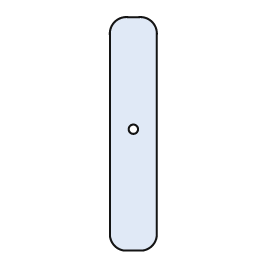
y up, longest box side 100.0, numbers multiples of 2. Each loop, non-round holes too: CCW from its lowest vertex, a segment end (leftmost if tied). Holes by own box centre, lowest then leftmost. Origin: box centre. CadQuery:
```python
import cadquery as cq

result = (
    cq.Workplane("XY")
    .moveTo(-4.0, -50.0)
    .lineTo(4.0, -50.0)
    .threePointArc((8.0, -48.0), (10.0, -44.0))
    .lineTo(10.0, 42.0)
    .threePointArc((8.0, 48.0), (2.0, 50.0))
    .lineTo(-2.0, 50.0)
    .threePointArc((-8.0, 48.0), (-10.0, 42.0))
    .lineTo(-10.0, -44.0)
    .threePointArc((-8.0, -48.0), (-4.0, -50.0))
    .close()
    .moveTo(0.0, 2.0)
    .circle(2.0)
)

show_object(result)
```